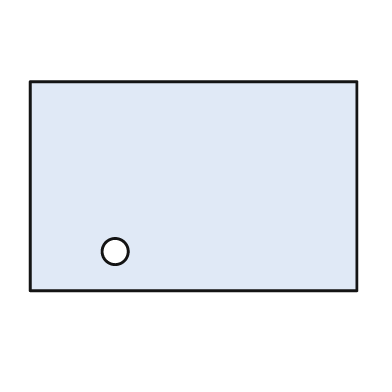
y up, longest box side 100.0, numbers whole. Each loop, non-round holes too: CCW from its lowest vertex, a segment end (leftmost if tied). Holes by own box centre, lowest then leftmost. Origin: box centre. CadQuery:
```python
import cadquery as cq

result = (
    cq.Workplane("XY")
    .moveTo(-50.0, -32.0)
    .lineTo(50.0, -32.0)
    .lineTo(50.0, 32.0)
    .lineTo(-50.0, 32.0)
    .close()
    .moveTo(-24.0, -20.0)
    .circle(4.0)
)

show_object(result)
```